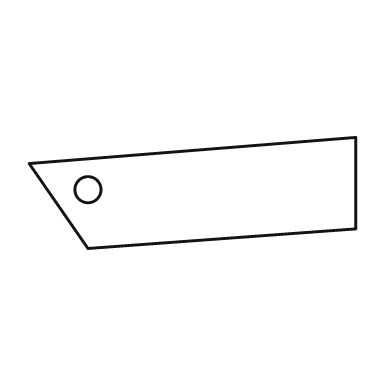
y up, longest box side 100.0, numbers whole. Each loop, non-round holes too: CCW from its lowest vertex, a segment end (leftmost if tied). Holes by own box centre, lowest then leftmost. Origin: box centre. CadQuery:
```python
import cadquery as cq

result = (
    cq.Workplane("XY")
    .moveTo(-32.0, -17.0)
    .lineTo(50.0, -11.0)
    .lineTo(50.0, 17.0)
    .lineTo(-50.0, 9.0)
    .close()
    .moveTo(-32.0, 1.0)
    .circle(4.0)
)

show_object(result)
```